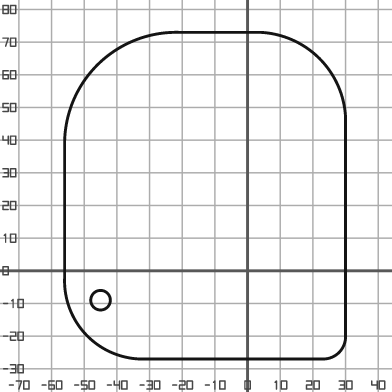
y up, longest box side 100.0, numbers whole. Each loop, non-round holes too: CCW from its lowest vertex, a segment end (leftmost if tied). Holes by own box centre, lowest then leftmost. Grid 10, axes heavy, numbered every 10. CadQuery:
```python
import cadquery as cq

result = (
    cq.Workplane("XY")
    .moveTo(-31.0, -27.0)
    .lineTo(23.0, -27.0)
    .threePointArc((28.0, -25.0), (30.0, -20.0))
    .lineTo(30.0, 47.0)
    .threePointArc((22.0, 65.0), (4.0, 73.0))
    .lineTo(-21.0, 73.0)
    .threePointArc((-46.0, 63.0), (-56.0, 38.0))
    .lineTo(-56.0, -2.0)
    .threePointArc((-49.0, -20.0), (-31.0, -27.0))
    .close()
    .moveTo(-45.0, -9.0)
    .circle(3.0)
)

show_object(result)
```